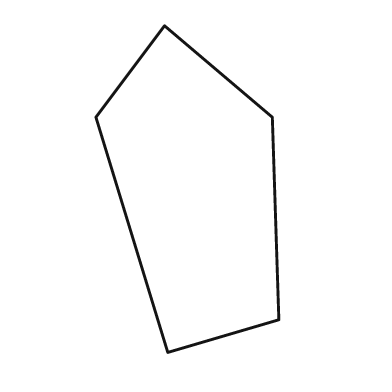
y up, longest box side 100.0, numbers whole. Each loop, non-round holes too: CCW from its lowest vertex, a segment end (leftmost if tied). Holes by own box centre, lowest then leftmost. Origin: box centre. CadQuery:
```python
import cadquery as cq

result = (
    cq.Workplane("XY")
    .moveTo(-6.0, -50.0)
    .lineTo(28.0, -40.0)
    .lineTo(26.0, 22.0)
    .lineTo(-7.0, 50.0)
    .lineTo(-28.0, 22.0)
    .close()
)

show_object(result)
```